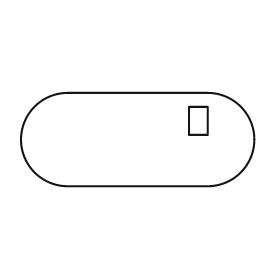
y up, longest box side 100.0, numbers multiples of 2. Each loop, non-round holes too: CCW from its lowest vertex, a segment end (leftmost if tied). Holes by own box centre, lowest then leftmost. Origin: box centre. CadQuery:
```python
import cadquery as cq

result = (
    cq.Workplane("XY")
    .moveTo(-30.0, -20.0)
    .lineTo(30.0, -20.0)
    .threePointArc((50.0, 0.0), (30.0, 20.0))
    .lineTo(-30.0, 20.0)
    .threePointArc((-50.0, 0.0), (-30.0, -20.0))
    .close()
    .moveTo(22.0, 2.0)
    .lineTo(30.0, 2.0)
    .lineTo(30.0, 14.0)
    .lineTo(22.0, 14.0)
    .close()
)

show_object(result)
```